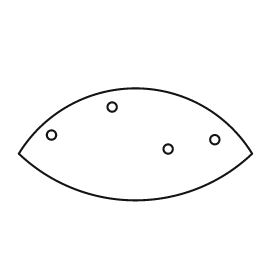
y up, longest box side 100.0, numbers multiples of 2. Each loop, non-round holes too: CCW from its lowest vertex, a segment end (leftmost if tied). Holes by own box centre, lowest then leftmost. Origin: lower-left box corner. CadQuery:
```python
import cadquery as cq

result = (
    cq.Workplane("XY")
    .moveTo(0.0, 20.0)
    .threePointArc((50.0, 0.0), (100.0, 20.0))
    .threePointArc((50.0, 48.0), (0.0, 20.0))
    .close()
    .moveTo(64.0, 22.0)
    .circle(2.0)
    .moveTo(84.0, 26.0)
    .circle(2.0)
    .moveTo(14.0, 28.0)
    .circle(2.0)
    .moveTo(40.0, 40.0)
    .circle(2.0)
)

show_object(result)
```